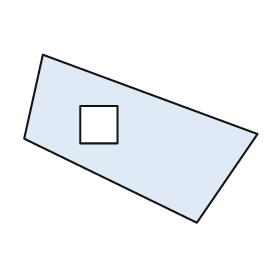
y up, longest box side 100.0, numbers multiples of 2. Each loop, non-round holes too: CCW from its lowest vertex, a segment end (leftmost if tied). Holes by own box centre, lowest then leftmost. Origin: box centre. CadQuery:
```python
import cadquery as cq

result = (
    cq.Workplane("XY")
    .moveTo(24.0, -36.0)
    .lineTo(50.0, 2.0)
    .lineTo(-42.0, 36.0)
    .lineTo(-50.0, 0.0)
    .close()
    .moveTo(-26.0, -2.0)
    .lineTo(-10.0, -2.0)
    .lineTo(-10.0, 14.0)
    .lineTo(-26.0, 14.0)
    .close()
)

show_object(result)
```